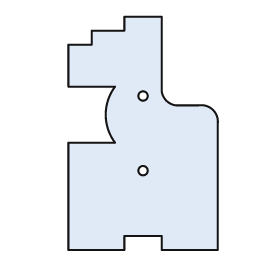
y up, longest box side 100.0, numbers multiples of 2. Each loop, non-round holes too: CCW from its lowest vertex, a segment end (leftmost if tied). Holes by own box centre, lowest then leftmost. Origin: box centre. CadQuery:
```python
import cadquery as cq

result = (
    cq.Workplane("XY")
    .moveTo(-32.0, -50.0)
    .lineTo(-8.0, -50.0)
    .lineTo(-8.0, -44.0)
    .lineTo(8.0, -44.0)
    .lineTo(8.0, -50.0)
    .lineTo(32.0, -50.0)
    .lineTo(32.0, 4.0)
    .threePointArc((30.0, 10.0), (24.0, 12.0))
    .lineTo(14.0, 12.0)
    .threePointArc((10.0, 14.0), (8.0, 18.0))
    .lineTo(8.0, 50.0)
    .lineTo(-8.0, 50.0)
    .lineTo(-8.0, 44.0)
    .lineTo(-22.0, 44.0)
    .lineTo(-22.0, 38.0)
    .lineTo(-32.0, 38.0)
    .lineTo(-32.0, 20.0)
    .lineTo(-12.0, 20.0)
    .threePointArc((-16.0, 8.0), (-12.0, -4.0))
    .lineTo(-32.0, -4.0)
    .close()
    .moveTo(0.0, -16.0)
    .circle(2.0)
    .moveTo(0.0, 16.0)
    .circle(2.0)
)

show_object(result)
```